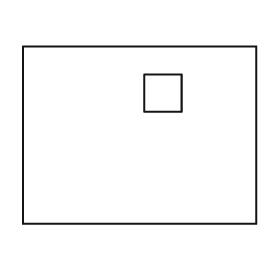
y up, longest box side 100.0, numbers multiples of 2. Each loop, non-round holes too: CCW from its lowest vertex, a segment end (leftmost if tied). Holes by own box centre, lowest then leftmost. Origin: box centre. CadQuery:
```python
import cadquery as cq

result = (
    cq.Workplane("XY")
    .moveTo(-50.0, -38.0)
    .lineTo(50.0, -38.0)
    .lineTo(50.0, 38.0)
    .lineTo(-50.0, 38.0)
    .close()
    .moveTo(2.0, 10.0)
    .lineTo(18.0, 10.0)
    .lineTo(18.0, 26.0)
    .lineTo(2.0, 26.0)
    .close()
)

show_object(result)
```